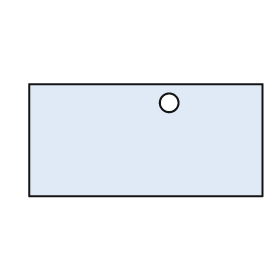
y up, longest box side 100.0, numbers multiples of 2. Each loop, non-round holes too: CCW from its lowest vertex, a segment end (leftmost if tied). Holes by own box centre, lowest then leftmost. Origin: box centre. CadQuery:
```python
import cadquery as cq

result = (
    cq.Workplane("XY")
    .moveTo(-50.0, -24.0)
    .lineTo(50.0, -24.0)
    .lineTo(50.0, 24.0)
    .lineTo(-50.0, 24.0)
    .close()
    .moveTo(10.0, 16.0)
    .circle(4.0)
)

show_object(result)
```